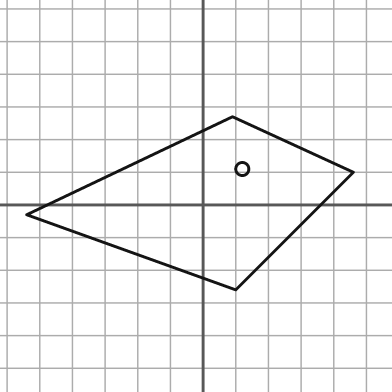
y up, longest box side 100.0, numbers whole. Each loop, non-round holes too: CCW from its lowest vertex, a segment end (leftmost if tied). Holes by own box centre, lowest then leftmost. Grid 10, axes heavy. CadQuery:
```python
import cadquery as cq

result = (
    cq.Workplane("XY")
    .moveTo(10.0, -26.0)
    .lineTo(46.0, 10.0)
    .lineTo(9.0, 27.0)
    .lineTo(-54.0, -3.0)
    .close()
    .moveTo(12.0, 11.0)
    .circle(2.0)
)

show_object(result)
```